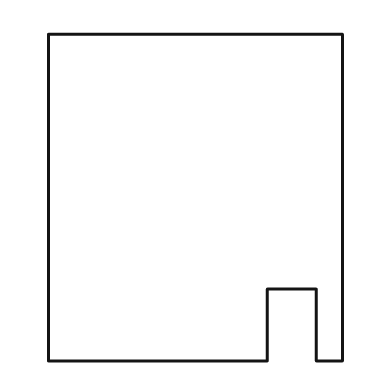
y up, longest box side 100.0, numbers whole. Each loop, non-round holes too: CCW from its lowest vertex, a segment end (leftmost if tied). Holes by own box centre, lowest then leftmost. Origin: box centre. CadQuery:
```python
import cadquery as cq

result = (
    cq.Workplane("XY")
    .moveTo(-45.0, -50.0)
    .lineTo(22.0, -50.0)
    .lineTo(22.0, -28.0)
    .lineTo(37.0, -28.0)
    .lineTo(37.0, -50.0)
    .lineTo(45.0, -50.0)
    .lineTo(45.0, 50.0)
    .lineTo(-45.0, 50.0)
    .close()
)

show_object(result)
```